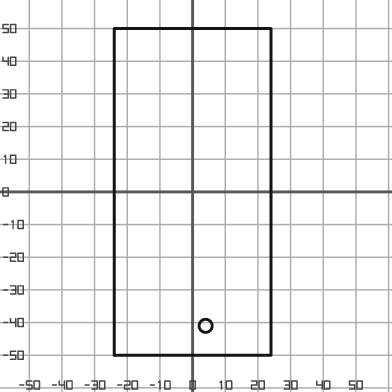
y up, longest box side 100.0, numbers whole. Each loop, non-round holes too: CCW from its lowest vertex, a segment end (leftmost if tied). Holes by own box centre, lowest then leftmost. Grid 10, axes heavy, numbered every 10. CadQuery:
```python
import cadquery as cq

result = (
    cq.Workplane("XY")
    .moveTo(-24.0, -50.0)
    .lineTo(24.0, -50.0)
    .lineTo(24.0, 50.0)
    .lineTo(-24.0, 50.0)
    .close()
    .moveTo(4.0, -41.0)
    .circle(2.0)
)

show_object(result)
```